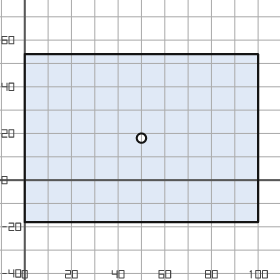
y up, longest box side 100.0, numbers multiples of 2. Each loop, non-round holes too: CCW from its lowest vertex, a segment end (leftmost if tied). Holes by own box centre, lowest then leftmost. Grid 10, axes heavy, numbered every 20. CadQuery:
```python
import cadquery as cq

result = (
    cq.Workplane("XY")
    .moveTo(0.0, -18.0)
    .lineTo(100.0, -18.0)
    .lineTo(100.0, 54.0)
    .lineTo(0.0, 54.0)
    .close()
    .moveTo(50.0, 18.0)
    .circle(2.0)
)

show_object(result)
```